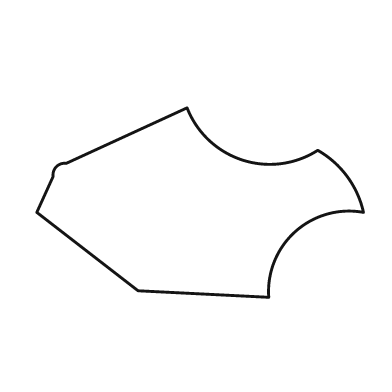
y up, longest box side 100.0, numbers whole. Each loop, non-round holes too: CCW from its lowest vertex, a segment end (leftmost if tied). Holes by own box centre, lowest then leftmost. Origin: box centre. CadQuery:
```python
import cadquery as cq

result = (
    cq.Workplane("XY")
    .moveTo(21.0, -29.0)
    .threePointArc((29.0, -9.0), (50.0, -3.0))
    .threePointArc((45.0, 8.0), (36.0, 16.0))
    .threePointArc((13.0, 13.0), (-4.0, 29.0))
    .lineTo(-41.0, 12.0)
    .threePointArc((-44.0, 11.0), (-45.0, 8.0))
    .lineTo(-50.0, -3.0)
    .lineTo(-19.0, -27.0)
    .close()
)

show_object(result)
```